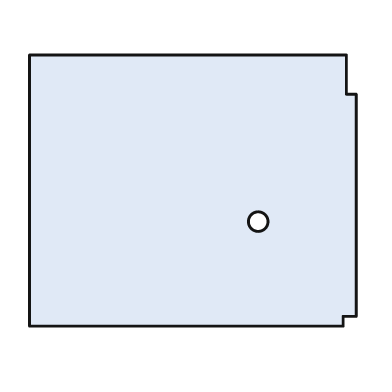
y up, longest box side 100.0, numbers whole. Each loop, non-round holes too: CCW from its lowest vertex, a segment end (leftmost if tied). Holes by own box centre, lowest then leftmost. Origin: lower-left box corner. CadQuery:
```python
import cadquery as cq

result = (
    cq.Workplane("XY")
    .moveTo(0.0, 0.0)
    .lineTo(96.0, 0.0)
    .lineTo(96.0, 3.0)
    .lineTo(100.0, 3.0)
    .lineTo(100.0, 71.0)
    .lineTo(97.0, 71.0)
    .lineTo(97.0, 83.0)
    .lineTo(0.0, 83.0)
    .close()
    .moveTo(70.0, 32.0)
    .circle(3.0)
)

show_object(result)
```